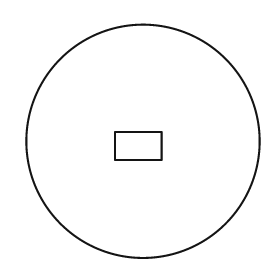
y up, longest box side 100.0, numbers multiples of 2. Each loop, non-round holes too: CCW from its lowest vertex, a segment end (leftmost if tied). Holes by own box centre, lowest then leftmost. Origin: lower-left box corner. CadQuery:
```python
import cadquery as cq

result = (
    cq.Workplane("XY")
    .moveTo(50.0, 50.0)
    .circle(50.0)
    .moveTo(38.0, 42.0)
    .lineTo(58.0, 42.0)
    .lineTo(58.0, 54.0)
    .lineTo(38.0, 54.0)
    .close()
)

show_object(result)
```